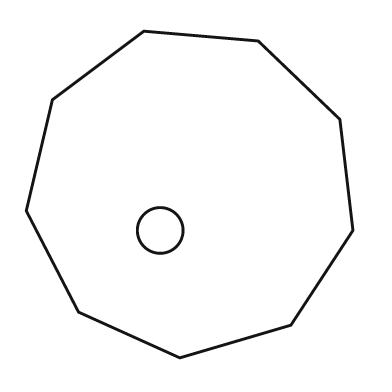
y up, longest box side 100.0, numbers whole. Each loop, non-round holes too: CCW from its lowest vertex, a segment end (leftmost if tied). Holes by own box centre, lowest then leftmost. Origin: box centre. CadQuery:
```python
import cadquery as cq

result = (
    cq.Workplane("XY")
    .moveTo(-3.0, -50.0)
    .lineTo(31.0, -40.0)
    .lineTo(50.0, -11.0)
    .lineTo(46.0, 23.0)
    .lineTo(21.0, 47.0)
    .lineTo(-14.0, 50.0)
    .lineTo(-42.0, 29.0)
    .lineTo(-50.0, -5.0)
    .lineTo(-34.0, -36.0)
    .close()
    .moveTo(-9.0, -11.0)
    .circle(7.0)
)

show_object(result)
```